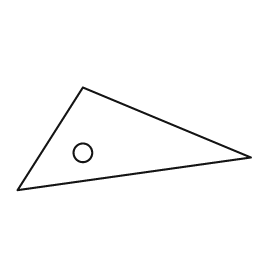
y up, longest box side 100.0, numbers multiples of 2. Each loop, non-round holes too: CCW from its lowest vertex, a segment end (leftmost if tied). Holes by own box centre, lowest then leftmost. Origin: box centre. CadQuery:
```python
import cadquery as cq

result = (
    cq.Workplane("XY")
    .moveTo(-50.0, -22.0)
    .lineTo(50.0, -8.0)
    .lineTo(-22.0, 22.0)
    .close()
    .moveTo(-22.0, -6.0)
    .circle(4.0)
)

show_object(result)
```